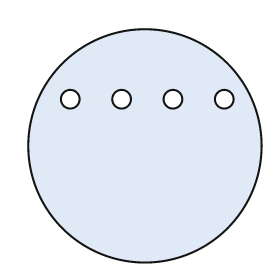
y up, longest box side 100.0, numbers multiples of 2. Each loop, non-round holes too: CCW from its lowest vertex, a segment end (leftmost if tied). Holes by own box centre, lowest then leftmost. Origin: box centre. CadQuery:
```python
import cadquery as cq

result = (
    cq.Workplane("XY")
    .moveTo(0.0, 0.0)
    .circle(50.0)
    .moveTo(-32.0, 20.0)
    .circle(4.0)
    .moveTo(-10.0, 20.0)
    .circle(4.0)
    .moveTo(12.0, 20.0)
    .circle(4.0)
    .moveTo(34.0, 20.0)
    .circle(4.0)
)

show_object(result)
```